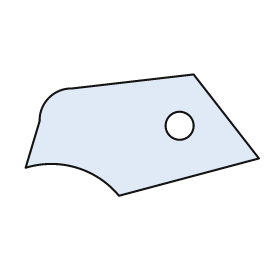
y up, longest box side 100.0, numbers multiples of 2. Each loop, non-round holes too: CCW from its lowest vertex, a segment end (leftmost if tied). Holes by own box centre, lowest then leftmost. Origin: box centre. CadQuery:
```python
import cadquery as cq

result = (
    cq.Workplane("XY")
    .moveTo(-10.0, -26.0)
    .lineTo(50.0, -10.0)
    .lineTo(22.0, 26.0)
    .lineTo(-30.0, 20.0)
    .threePointArc((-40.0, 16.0), (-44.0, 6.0))
    .lineTo(-50.0, -14.0)
    .threePointArc((-28.0, -14.0), (-10.0, -26.0))
    .close()
    .moveTo(16.0, 4.0)
    .circle(6.0)
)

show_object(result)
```